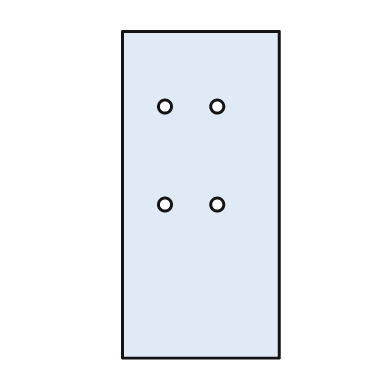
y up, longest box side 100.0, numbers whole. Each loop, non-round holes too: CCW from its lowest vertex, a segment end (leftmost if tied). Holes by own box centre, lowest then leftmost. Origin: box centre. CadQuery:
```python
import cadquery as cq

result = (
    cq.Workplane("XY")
    .moveTo(-24.0, -50.0)
    .lineTo(24.0, -50.0)
    .lineTo(24.0, 50.0)
    .lineTo(-24.0, 50.0)
    .close()
    .moveTo(-11.0, -3.0)
    .circle(2.0)
    .moveTo(5.0, -3.0)
    .circle(2.0)
    .moveTo(-11.0, 27.0)
    .circle(2.0)
    .moveTo(5.0, 27.0)
    .circle(2.0)
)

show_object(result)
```